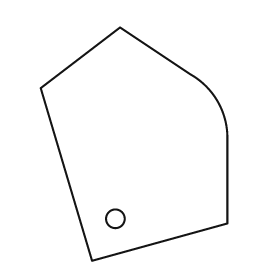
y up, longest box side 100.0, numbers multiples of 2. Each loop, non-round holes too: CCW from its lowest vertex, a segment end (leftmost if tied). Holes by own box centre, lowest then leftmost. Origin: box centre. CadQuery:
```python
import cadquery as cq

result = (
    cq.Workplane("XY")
    .moveTo(-18.0, -50.0)
    .lineTo(40.0, -34.0)
    .lineTo(40.0, 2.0)
    .threePointArc((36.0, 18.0), (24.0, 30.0))
    .lineTo(-6.0, 50.0)
    .lineTo(-40.0, 24.0)
    .close()
    .moveTo(-8.0, -32.0)
    .circle(4.0)
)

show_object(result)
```